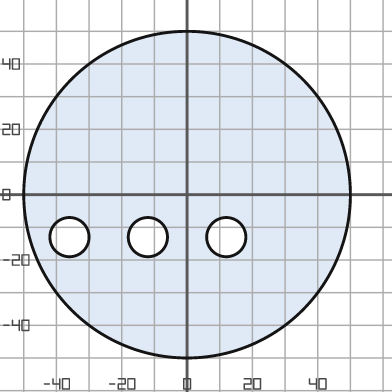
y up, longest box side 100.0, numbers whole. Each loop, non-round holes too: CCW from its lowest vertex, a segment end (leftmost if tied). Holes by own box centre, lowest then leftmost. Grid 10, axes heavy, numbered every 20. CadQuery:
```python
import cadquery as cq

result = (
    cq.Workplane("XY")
    .moveTo(0.0, 0.0)
    .circle(50.0)
    .moveTo(-36.0, -13.0)
    .circle(6.0)
    .moveTo(-12.0, -13.0)
    .circle(6.0)
    .moveTo(12.0, -13.0)
    .circle(6.0)
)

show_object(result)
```